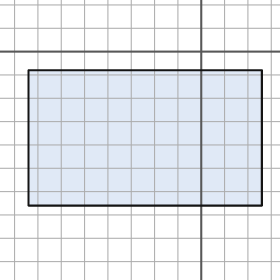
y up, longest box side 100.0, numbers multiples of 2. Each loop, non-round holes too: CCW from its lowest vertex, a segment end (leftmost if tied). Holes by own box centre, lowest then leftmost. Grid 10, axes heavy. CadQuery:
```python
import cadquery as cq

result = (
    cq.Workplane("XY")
    .moveTo(-74.0, -66.0)
    .lineTo(26.0, -66.0)
    .lineTo(26.0, -8.0)
    .lineTo(-74.0, -8.0)
    .close()
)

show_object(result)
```